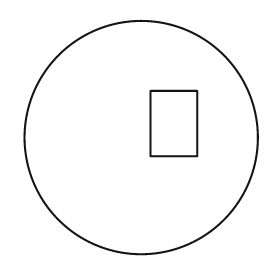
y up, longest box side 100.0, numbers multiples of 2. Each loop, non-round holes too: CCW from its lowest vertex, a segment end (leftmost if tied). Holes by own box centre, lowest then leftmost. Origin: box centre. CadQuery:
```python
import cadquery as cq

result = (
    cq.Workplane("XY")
    .moveTo(0.0, 0.0)
    .circle(50.0)
    .moveTo(4.0, -8.0)
    .lineTo(24.0, -8.0)
    .lineTo(24.0, 20.0)
    .lineTo(4.0, 20.0)
    .close()
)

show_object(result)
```